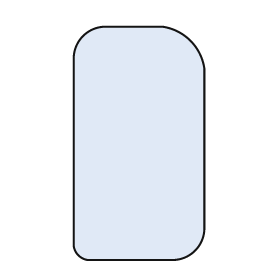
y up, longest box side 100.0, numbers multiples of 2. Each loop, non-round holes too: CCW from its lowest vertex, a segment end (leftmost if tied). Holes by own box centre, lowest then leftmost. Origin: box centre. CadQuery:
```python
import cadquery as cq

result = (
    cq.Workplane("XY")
    .moveTo(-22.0, -50.0)
    .lineTo(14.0, -50.0)
    .threePointArc((24.0, -46.0), (28.0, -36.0))
    .lineTo(28.0, 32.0)
    .threePointArc((22.0, 44.0), (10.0, 50.0))
    .lineTo(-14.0, 50.0)
    .threePointArc((-24.0, 46.0), (-28.0, 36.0))
    .lineTo(-28.0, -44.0)
    .threePointArc((-26.0, -48.0), (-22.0, -50.0))
    .close()
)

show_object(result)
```